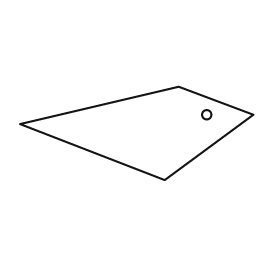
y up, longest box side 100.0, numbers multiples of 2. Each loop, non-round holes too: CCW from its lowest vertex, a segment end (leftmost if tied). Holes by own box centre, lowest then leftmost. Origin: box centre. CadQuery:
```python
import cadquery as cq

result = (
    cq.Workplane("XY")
    .moveTo(12.0, -20.0)
    .lineTo(50.0, 8.0)
    .lineTo(18.0, 20.0)
    .lineTo(-50.0, 4.0)
    .close()
    .moveTo(30.0, 8.0)
    .circle(2.0)
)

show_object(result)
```